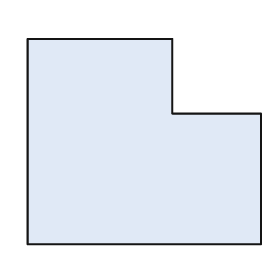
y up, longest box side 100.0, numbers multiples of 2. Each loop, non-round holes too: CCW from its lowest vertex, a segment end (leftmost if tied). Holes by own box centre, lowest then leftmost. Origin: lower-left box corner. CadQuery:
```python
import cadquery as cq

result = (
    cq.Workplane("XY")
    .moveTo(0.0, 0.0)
    .lineTo(100.0, 0.0)
    .lineTo(100.0, 56.0)
    .lineTo(62.0, 56.0)
    .lineTo(62.0, 88.0)
    .lineTo(0.0, 88.0)
    .close()
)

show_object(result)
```